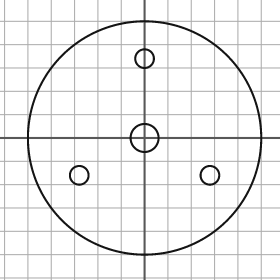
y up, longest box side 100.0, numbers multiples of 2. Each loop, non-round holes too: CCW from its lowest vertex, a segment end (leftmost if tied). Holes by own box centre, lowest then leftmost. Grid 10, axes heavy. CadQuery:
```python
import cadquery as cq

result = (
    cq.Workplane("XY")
    .moveTo(0.0, 0.0)
    .circle(50.0)
    .moveTo(-28.0, -16.0)
    .circle(4.0)
    .moveTo(28.0, -16.0)
    .circle(4.0)
    .moveTo(0.0, 0.0)
    .circle(6.0)
    .moveTo(0.0, 34.0)
    .circle(4.0)
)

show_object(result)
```